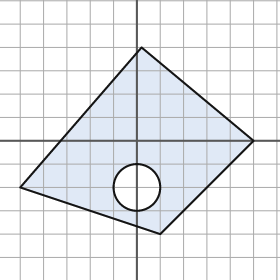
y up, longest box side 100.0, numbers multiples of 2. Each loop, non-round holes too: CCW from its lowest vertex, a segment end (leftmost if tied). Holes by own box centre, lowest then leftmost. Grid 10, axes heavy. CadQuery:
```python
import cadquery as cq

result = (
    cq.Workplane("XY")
    .moveTo(10.0, -40.0)
    .lineTo(50.0, 0.0)
    .lineTo(2.0, 40.0)
    .lineTo(-50.0, -20.0)
    .close()
    .moveTo(0.0, -20.0)
    .circle(10.0)
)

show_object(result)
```